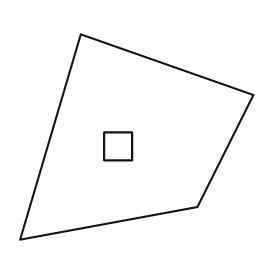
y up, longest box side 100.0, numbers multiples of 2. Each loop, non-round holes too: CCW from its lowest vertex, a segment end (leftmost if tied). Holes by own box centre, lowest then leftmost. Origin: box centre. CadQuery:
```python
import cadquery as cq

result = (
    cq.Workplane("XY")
    .moveTo(-50.0, -44.0)
    .lineTo(26.0, -30.0)
    .lineTo(50.0, 18.0)
    .lineTo(-24.0, 44.0)
    .close()
    .moveTo(-14.0, -10.0)
    .lineTo(-2.0, -10.0)
    .lineTo(-2.0, 2.0)
    .lineTo(-14.0, 2.0)
    .close()
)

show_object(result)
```